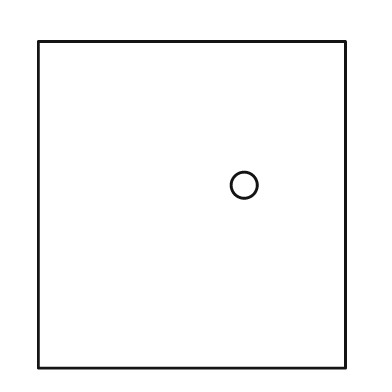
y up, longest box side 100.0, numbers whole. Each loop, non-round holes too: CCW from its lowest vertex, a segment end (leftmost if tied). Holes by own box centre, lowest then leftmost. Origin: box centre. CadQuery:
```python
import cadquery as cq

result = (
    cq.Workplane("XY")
    .moveTo(-47.0, -50.0)
    .lineTo(47.0, -50.0)
    .lineTo(47.0, 50.0)
    .lineTo(-47.0, 50.0)
    .close()
    .moveTo(16.0, 6.0)
    .circle(4.0)
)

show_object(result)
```